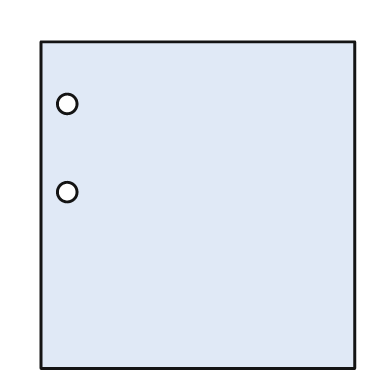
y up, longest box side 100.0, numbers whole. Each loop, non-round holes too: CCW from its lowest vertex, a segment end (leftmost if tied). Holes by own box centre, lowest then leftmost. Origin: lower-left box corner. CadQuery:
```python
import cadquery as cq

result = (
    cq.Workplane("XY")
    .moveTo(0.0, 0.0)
    .lineTo(96.0, 0.0)
    .lineTo(96.0, 100.0)
    .lineTo(0.0, 100.0)
    .close()
    .moveTo(8.0, 54.0)
    .circle(3.0)
    .moveTo(8.0, 81.0)
    .circle(3.0)
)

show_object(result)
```